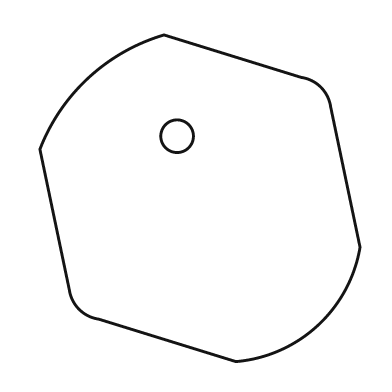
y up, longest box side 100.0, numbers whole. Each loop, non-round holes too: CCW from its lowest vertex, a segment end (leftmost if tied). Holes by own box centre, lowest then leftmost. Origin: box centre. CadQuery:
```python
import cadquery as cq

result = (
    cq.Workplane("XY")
    .moveTo(11.0, -50.0)
    .threePointArc((36.0, -39.0), (49.0, -15.0))
    .lineTo(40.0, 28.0)
    .threePointArc((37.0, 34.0), (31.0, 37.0))
    .lineTo(-11.0, 50.0)
    .threePointArc((-34.0, 37.0), (-49.0, 15.0))
    .lineTo(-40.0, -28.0)
    .threePointArc((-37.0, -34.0), (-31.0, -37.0))
    .close()
    .moveTo(-7.0, 19.0)
    .circle(5.0)
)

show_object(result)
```